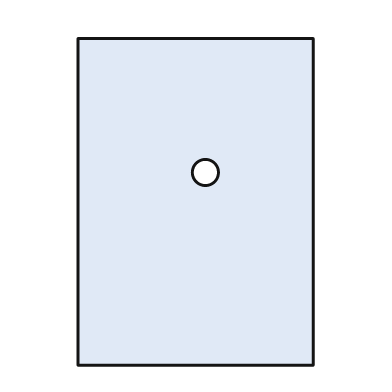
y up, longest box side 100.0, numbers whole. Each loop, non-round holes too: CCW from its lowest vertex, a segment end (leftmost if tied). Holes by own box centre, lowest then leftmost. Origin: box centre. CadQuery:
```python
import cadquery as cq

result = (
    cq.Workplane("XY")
    .moveTo(-36.0, -50.0)
    .lineTo(36.0, -50.0)
    .lineTo(36.0, 50.0)
    .lineTo(-36.0, 50.0)
    .close()
    .moveTo(3.0, 9.0)
    .circle(4.0)
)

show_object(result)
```